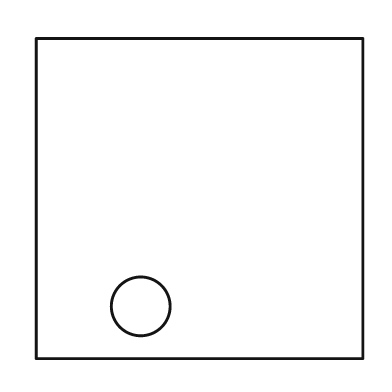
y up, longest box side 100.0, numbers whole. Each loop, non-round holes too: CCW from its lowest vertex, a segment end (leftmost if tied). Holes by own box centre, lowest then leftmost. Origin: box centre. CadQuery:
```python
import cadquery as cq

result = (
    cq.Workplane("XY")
    .moveTo(-50.0, -49.0)
    .lineTo(50.0, -49.0)
    .lineTo(50.0, 49.0)
    .lineTo(-50.0, 49.0)
    .close()
    .moveTo(-18.0, -33.0)
    .circle(9.0)
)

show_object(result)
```